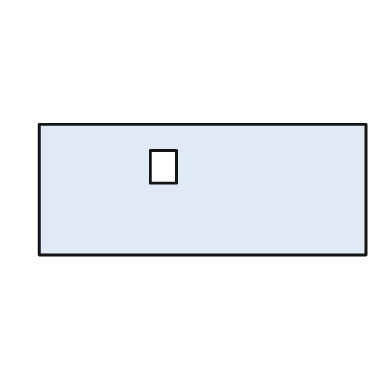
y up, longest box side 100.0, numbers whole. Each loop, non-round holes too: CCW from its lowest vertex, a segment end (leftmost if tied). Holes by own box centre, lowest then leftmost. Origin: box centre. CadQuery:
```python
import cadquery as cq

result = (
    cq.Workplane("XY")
    .moveTo(-50.0, -20.0)
    .lineTo(50.0, -20.0)
    .lineTo(50.0, 20.0)
    .lineTo(-50.0, 20.0)
    .close()
    .moveTo(-16.0, 2.0)
    .lineTo(-8.0, 2.0)
    .lineTo(-8.0, 12.0)
    .lineTo(-16.0, 12.0)
    .close()
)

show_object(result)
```